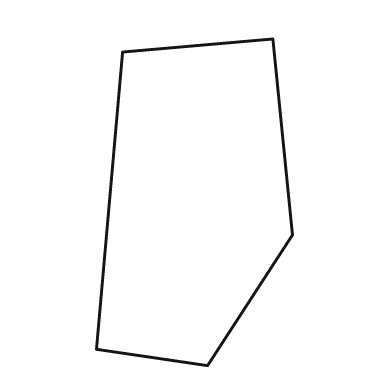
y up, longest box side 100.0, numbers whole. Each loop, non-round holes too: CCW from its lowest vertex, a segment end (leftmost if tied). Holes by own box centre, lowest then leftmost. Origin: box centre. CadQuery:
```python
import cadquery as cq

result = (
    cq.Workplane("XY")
    .moveTo(4.0, -50.0)
    .lineTo(30.0, -10.0)
    .lineTo(24.0, 50.0)
    .lineTo(-22.0, 46.0)
    .lineTo(-30.0, -45.0)
    .close()
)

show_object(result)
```